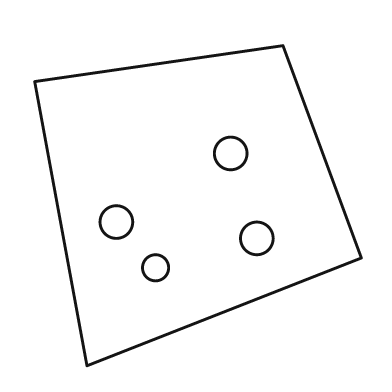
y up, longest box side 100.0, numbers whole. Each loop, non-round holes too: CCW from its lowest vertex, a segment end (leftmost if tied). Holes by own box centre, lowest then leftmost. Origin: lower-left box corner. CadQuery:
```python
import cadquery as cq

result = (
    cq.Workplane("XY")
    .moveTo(16.0, 0.0)
    .lineTo(100.0, 33.0)
    .lineTo(76.0, 98.0)
    .lineTo(0.0, 87.0)
    .close()
    .moveTo(37.0, 30.0)
    .circle(4.0)
    .moveTo(68.0, 39.0)
    .circle(5.0)
    .moveTo(25.0, 44.0)
    .circle(5.0)
    .moveTo(60.0, 65.0)
    .circle(5.0)
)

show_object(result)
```